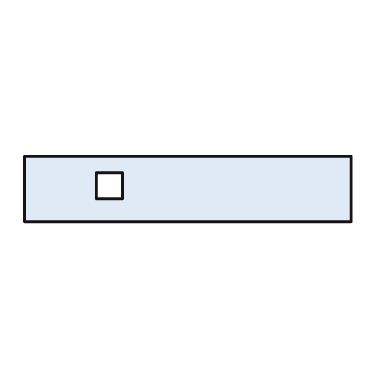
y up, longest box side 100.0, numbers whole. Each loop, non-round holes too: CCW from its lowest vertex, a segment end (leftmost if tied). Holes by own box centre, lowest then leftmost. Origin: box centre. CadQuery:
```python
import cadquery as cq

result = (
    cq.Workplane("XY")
    .moveTo(-50.0, -10.0)
    .lineTo(50.0, -10.0)
    .lineTo(50.0, 10.0)
    .lineTo(-50.0, 10.0)
    .close()
    .moveTo(-28.0, -3.0)
    .lineTo(-20.0, -3.0)
    .lineTo(-20.0, 5.0)
    .lineTo(-28.0, 5.0)
    .close()
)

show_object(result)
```